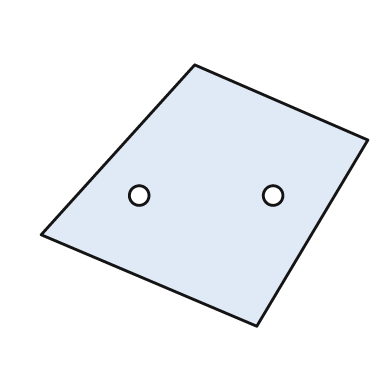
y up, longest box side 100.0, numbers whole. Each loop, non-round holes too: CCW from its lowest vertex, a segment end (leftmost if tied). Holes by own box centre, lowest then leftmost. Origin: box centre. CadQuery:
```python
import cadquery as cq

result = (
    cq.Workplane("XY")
    .moveTo(16.0, -40.0)
    .lineTo(50.0, 17.0)
    .lineTo(-3.0, 40.0)
    .lineTo(-50.0, -12.0)
    .close()
    .moveTo(-20.0, 0.0)
    .circle(3.0)
    .moveTo(21.0, 0.0)
    .circle(3.0)
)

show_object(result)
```